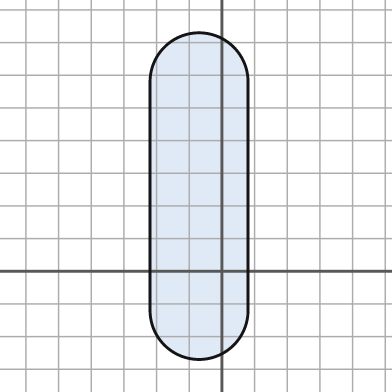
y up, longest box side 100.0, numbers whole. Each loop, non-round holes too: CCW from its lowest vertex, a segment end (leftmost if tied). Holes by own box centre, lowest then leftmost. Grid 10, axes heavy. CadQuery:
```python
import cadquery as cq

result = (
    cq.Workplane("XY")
    .moveTo(-22.0, -12.0)
    .threePointArc((-7.0, -27.0), (8.0, -12.0))
    .lineTo(8.0, 58.0)
    .threePointArc((-7.0, 73.0), (-22.0, 58.0))
    .close()
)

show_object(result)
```